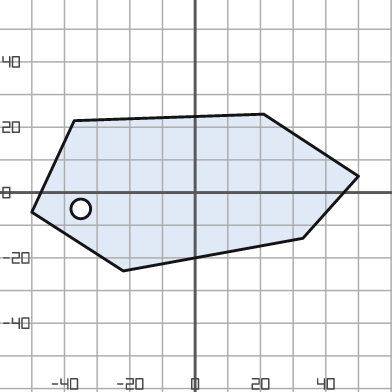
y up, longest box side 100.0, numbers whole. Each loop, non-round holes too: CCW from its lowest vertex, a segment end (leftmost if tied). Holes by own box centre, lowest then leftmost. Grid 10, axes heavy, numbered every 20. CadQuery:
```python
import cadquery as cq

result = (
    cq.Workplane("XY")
    .moveTo(-22.0, -24.0)
    .lineTo(33.0, -14.0)
    .lineTo(50.0, 5.0)
    .lineTo(21.0, 24.0)
    .lineTo(-37.0, 22.0)
    .lineTo(-50.0, -6.0)
    .close()
    .moveTo(-35.0, -5.0)
    .circle(3.0)
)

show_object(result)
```